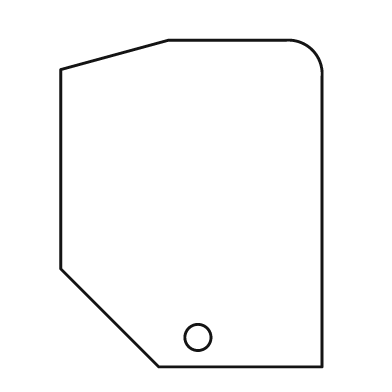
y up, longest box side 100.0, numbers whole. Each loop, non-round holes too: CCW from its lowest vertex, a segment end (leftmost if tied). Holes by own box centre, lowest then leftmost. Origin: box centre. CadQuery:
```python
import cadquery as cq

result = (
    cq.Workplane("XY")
    .moveTo(-10.0, -50.0)
    .lineTo(40.0, -50.0)
    .lineTo(40.0, 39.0)
    .threePointArc((37.0, 47.0), (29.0, 50.0))
    .lineTo(-7.0, 50.0)
    .lineTo(-40.0, 41.0)
    .lineTo(-40.0, -20.0)
    .close()
    .moveTo(2.0, -41.0)
    .circle(4.0)
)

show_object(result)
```